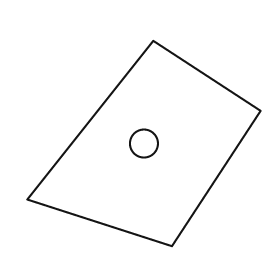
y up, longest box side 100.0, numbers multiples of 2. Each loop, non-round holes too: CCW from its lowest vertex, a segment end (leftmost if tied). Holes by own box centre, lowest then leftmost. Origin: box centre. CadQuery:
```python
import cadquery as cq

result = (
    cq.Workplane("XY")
    .moveTo(12.0, -44.0)
    .lineTo(50.0, 14.0)
    .lineTo(4.0, 44.0)
    .lineTo(-50.0, -24.0)
    .close()
    .moveTo(0.0, 0.0)
    .circle(6.0)
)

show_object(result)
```